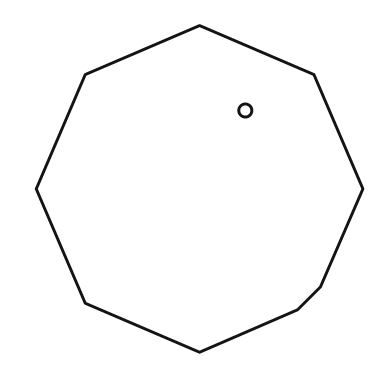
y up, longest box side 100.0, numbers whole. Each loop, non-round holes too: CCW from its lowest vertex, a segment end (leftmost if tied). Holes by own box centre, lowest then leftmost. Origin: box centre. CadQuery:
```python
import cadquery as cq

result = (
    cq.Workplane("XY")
    .moveTo(0.0, -50.0)
    .lineTo(30.0, -37.0)
    .lineTo(37.0, -30.0)
    .lineTo(50.0, 0.0)
    .lineTo(35.0, 35.0)
    .lineTo(0.0, 50.0)
    .lineTo(-35.0, 35.0)
    .lineTo(-50.0, 0.0)
    .lineTo(-35.0, -35.0)
    .close()
    .moveTo(14.0, 24.0)
    .circle(2.0)
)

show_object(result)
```